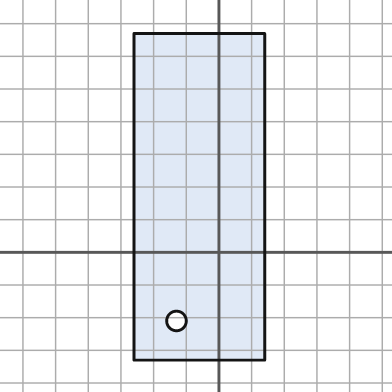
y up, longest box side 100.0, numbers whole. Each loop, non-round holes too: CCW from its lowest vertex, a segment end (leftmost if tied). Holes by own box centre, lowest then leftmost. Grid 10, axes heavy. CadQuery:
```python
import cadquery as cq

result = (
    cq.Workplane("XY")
    .moveTo(-26.0, -33.0)
    .lineTo(14.0, -33.0)
    .lineTo(14.0, 67.0)
    .lineTo(-26.0, 67.0)
    .close()
    .moveTo(-13.0, -21.0)
    .circle(3.0)
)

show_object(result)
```